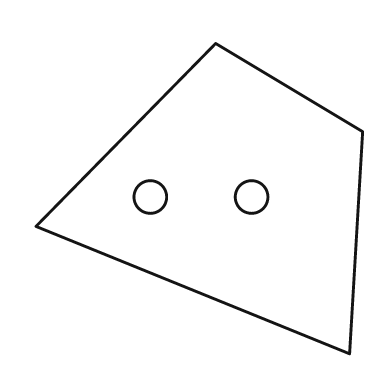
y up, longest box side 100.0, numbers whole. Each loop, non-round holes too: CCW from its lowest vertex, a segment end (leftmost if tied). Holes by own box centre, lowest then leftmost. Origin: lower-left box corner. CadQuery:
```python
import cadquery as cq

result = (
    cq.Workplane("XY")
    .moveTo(96.0, 0.0)
    .lineTo(100.0, 68.0)
    .lineTo(55.0, 95.0)
    .lineTo(0.0, 39.0)
    .close()
    .moveTo(35.0, 48.0)
    .circle(5.0)
    .moveTo(66.0, 48.0)
    .circle(5.0)
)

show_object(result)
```